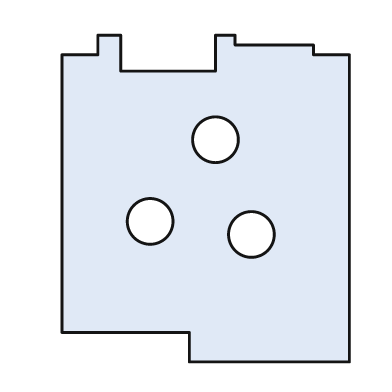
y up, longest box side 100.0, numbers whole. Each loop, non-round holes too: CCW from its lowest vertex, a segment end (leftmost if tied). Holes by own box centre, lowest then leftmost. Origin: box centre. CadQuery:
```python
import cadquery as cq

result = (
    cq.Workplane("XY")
    .moveTo(-5.0, -50.0)
    .lineTo(44.0, -50.0)
    .lineTo(44.0, 44.0)
    .lineTo(33.0, 44.0)
    .lineTo(33.0, 47.0)
    .lineTo(9.0, 47.0)
    .lineTo(9.0, 50.0)
    .lineTo(3.0, 50.0)
    .lineTo(3.0, 39.0)
    .lineTo(-26.0, 39.0)
    .lineTo(-26.0, 50.0)
    .lineTo(-33.0, 50.0)
    .lineTo(-33.0, 44.0)
    .lineTo(-44.0, 44.0)
    .lineTo(-44.0, -41.0)
    .lineTo(-5.0, -41.0)
    .close()
    .moveTo(14.0, -11.0)
    .circle(7.0)
    .moveTo(-17.0, -7.0)
    .circle(7.0)
    .moveTo(3.0, 18.0)
    .circle(7.0)
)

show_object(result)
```